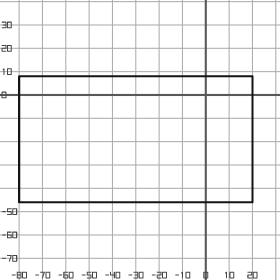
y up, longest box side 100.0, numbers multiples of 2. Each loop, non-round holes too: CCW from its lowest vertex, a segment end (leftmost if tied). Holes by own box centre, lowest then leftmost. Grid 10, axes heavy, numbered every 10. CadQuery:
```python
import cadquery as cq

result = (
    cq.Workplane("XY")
    .moveTo(-80.0, -46.0)
    .lineTo(20.0, -46.0)
    .lineTo(20.0, 8.0)
    .lineTo(-80.0, 8.0)
    .close()
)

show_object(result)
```